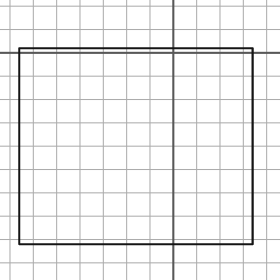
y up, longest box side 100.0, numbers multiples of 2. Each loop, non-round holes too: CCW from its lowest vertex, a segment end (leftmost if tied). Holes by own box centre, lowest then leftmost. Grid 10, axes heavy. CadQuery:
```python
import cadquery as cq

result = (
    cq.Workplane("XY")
    .moveTo(-66.0, -82.0)
    .lineTo(34.0, -82.0)
    .lineTo(34.0, 2.0)
    .lineTo(-66.0, 2.0)
    .close()
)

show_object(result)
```